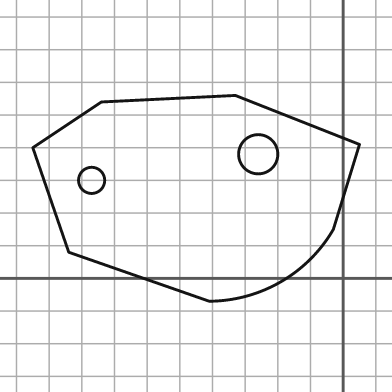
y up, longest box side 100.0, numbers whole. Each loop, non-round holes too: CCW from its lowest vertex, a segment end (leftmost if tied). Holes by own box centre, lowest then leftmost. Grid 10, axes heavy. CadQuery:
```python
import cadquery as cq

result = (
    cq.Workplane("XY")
    .moveTo(-41.0, -7.0)
    .threePointArc((-19.0, -1.0), (-3.0, 15.0))
    .lineTo(5.0, 41.0)
    .lineTo(-33.0, 56.0)
    .lineTo(-74.0, 54.0)
    .lineTo(-95.0, 40.0)
    .lineTo(-84.0, 8.0)
    .close()
    .moveTo(-77.0, 30.0)
    .circle(4.0)
    .moveTo(-26.0, 38.0)
    .circle(6.0)
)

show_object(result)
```